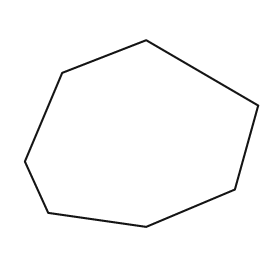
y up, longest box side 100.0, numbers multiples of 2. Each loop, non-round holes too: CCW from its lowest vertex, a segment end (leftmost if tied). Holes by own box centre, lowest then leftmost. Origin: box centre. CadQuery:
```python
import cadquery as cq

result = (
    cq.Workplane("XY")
    .moveTo(2.0, -40.0)
    .lineTo(40.0, -24.0)
    .lineTo(50.0, 12.0)
    .lineTo(2.0, 40.0)
    .lineTo(-34.0, 26.0)
    .lineTo(-50.0, -12.0)
    .lineTo(-40.0, -34.0)
    .close()
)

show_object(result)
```